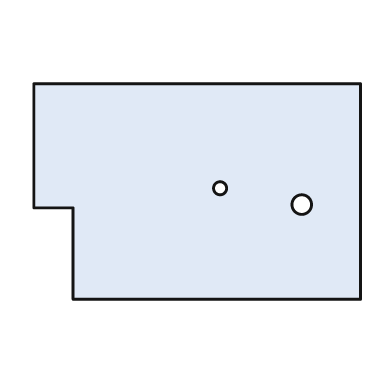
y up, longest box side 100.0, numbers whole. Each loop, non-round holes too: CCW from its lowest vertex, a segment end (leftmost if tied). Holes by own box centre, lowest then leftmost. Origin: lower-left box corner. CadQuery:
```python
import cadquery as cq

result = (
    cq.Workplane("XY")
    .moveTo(12.0, 0.0)
    .lineTo(100.0, 0.0)
    .lineTo(100.0, 66.0)
    .lineTo(0.0, 66.0)
    .lineTo(0.0, 28.0)
    .lineTo(12.0, 28.0)
    .close()
    .moveTo(82.0, 29.0)
    .circle(3.0)
    .moveTo(57.0, 34.0)
    .circle(2.0)
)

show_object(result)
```